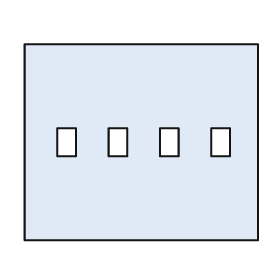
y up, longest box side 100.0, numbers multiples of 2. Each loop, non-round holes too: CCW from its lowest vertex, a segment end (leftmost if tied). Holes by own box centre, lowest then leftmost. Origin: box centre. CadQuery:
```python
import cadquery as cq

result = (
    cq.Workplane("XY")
    .moveTo(-50.0, -42.0)
    .lineTo(50.0, -42.0)
    .lineTo(50.0, 42.0)
    .lineTo(-50.0, 42.0)
    .close()
    .moveTo(-36.0, -6.0)
    .lineTo(-28.0, -6.0)
    .lineTo(-28.0, 6.0)
    .lineTo(-36.0, 6.0)
    .close()
    .moveTo(-14.0, -6.0)
    .lineTo(-6.0, -6.0)
    .lineTo(-6.0, 6.0)
    .lineTo(-14.0, 6.0)
    .close()
    .moveTo(8.0, -6.0)
    .lineTo(16.0, -6.0)
    .lineTo(16.0, 6.0)
    .lineTo(8.0, 6.0)
    .close()
    .moveTo(30.0, -6.0)
    .lineTo(38.0, -6.0)
    .lineTo(38.0, 6.0)
    .lineTo(30.0, 6.0)
    .close()
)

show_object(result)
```